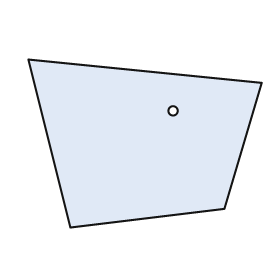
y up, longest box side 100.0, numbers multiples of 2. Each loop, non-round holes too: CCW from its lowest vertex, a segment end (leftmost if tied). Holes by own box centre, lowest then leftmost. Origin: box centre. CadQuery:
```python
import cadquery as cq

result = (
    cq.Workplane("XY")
    .moveTo(-32.0, -36.0)
    .lineTo(34.0, -28.0)
    .lineTo(50.0, 26.0)
    .lineTo(-50.0, 36.0)
    .close()
    .moveTo(12.0, 14.0)
    .circle(2.0)
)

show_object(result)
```